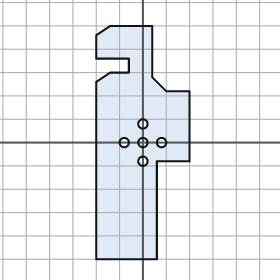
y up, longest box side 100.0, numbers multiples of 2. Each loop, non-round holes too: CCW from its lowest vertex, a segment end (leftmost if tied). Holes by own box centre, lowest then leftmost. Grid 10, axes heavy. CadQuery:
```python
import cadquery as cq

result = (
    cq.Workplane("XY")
    .moveTo(-20.0, -50.0)
    .lineTo(6.0, -50.0)
    .lineTo(6.0, -8.0)
    .lineTo(20.0, -8.0)
    .lineTo(20.0, 22.0)
    .lineTo(10.0, 22.0)
    .lineTo(4.0, 28.0)
    .lineTo(4.0, 50.0)
    .lineTo(-14.0, 50.0)
    .lineTo(-20.0, 46.0)
    .lineTo(-20.0, 36.0)
    .lineTo(-6.0, 36.0)
    .lineTo(-6.0, 30.0)
    .lineTo(-14.0, 30.0)
    .lineTo(-20.0, 26.0)
    .close()
    .moveTo(0.0, -8.0)
    .circle(2.0)
    .moveTo(-8.0, 0.0)
    .circle(2.0)
    .moveTo(0.0, 0.0)
    .circle(2.0)
    .moveTo(8.0, 0.0)
    .circle(2.0)
    .moveTo(0.0, 8.0)
    .circle(2.0)
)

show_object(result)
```